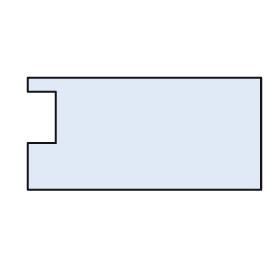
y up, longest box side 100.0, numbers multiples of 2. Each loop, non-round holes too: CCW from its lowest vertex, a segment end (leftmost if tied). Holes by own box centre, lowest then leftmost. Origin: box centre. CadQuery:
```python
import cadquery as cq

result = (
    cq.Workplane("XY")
    .moveTo(-50.0, -24.0)
    .lineTo(50.0, -24.0)
    .lineTo(50.0, 24.0)
    .lineTo(-50.0, 24.0)
    .lineTo(-50.0, 18.0)
    .lineTo(-38.0, 18.0)
    .lineTo(-38.0, -4.0)
    .lineTo(-50.0, -4.0)
    .close()
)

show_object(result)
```